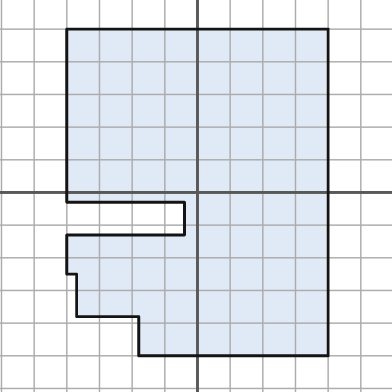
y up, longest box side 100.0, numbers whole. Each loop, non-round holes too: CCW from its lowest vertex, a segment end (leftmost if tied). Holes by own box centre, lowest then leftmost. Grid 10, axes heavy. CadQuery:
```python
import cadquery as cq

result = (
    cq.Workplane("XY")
    .moveTo(-18.0, -50.0)
    .lineTo(40.0, -50.0)
    .lineTo(40.0, 50.0)
    .lineTo(-40.0, 50.0)
    .lineTo(-40.0, -3.0)
    .lineTo(-4.0, -3.0)
    .lineTo(-4.0, -13.0)
    .lineTo(-40.0, -13.0)
    .lineTo(-40.0, -25.0)
    .lineTo(-37.0, -25.0)
    .lineTo(-37.0, -38.0)
    .lineTo(-18.0, -38.0)
    .close()
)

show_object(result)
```